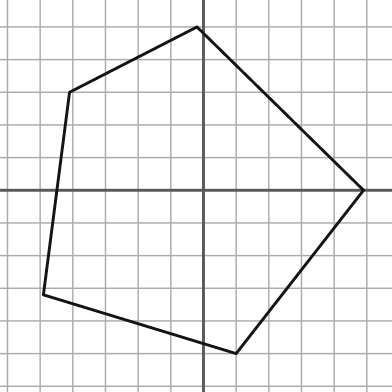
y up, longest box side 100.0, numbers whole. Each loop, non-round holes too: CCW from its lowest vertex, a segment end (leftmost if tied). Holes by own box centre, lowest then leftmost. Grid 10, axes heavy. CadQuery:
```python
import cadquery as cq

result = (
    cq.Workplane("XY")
    .moveTo(10.0, -50.0)
    .lineTo(49.0, 0.0)
    .lineTo(-2.0, 50.0)
    .lineTo(-41.0, 30.0)
    .lineTo(-49.0, -32.0)
    .close()
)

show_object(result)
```